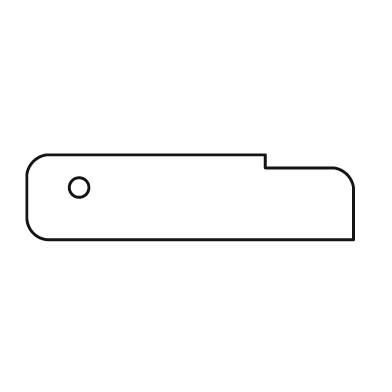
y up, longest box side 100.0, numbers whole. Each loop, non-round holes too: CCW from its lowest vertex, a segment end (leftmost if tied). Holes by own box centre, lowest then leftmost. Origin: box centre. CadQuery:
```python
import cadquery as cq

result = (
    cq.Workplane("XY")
    .moveTo(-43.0, -13.0)
    .lineTo(50.0, -13.0)
    .lineTo(50.0, 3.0)
    .threePointArc((48.0, 7.0), (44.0, 9.0))
    .lineTo(23.0, 9.0)
    .lineTo(23.0, 13.0)
    .lineTo(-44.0, 13.0)
    .threePointArc((-48.0, 11.0), (-50.0, 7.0))
    .lineTo(-50.0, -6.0)
    .threePointArc((-48.0, -11.0), (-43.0, -13.0))
    .close()
    .moveTo(-34.0, 3.0)
    .circle(3.0)
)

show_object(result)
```